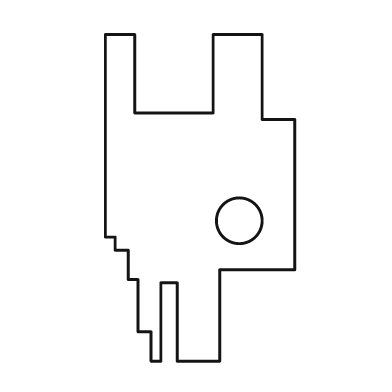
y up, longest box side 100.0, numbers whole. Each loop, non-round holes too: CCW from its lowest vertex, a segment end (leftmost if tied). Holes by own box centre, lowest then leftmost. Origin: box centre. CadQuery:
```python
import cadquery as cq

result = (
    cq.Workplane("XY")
    .moveTo(-15.0, -50.0)
    .lineTo(-12.0, -50.0)
    .lineTo(-12.0, -26.0)
    .lineTo(-7.0, -26.0)
    .lineTo(-7.0, -50.0)
    .lineTo(6.0, -50.0)
    .lineTo(6.0, -22.0)
    .lineTo(29.0, -22.0)
    .lineTo(29.0, 24.0)
    .lineTo(19.0, 24.0)
    .lineTo(19.0, 50.0)
    .lineTo(4.0, 50.0)
    .lineTo(4.0, 26.0)
    .lineTo(-20.0, 26.0)
    .lineTo(-20.0, 50.0)
    .lineTo(-29.0, 50.0)
    .lineTo(-29.0, -12.0)
    .lineTo(-26.0, -12.0)
    .lineTo(-26.0, -16.0)
    .lineTo(-22.0, -16.0)
    .lineTo(-22.0, -25.0)
    .lineTo(-19.0, -25.0)
    .lineTo(-19.0, -41.0)
    .lineTo(-15.0, -41.0)
    .close()
    .moveTo(12.0, -7.0)
    .circle(7.0)
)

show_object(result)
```